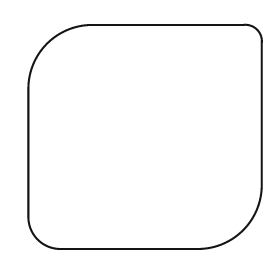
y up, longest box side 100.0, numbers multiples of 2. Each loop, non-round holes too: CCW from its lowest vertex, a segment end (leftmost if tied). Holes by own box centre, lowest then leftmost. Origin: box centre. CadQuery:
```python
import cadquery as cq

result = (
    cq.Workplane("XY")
    .moveTo(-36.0, -48.0)
    .lineTo(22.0, -48.0)
    .threePointArc((42.0, -40.0), (50.0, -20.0))
    .lineTo(50.0, 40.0)
    .threePointArc((48.0, 46.0), (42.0, 48.0))
    .lineTo(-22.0, 48.0)
    .threePointArc((-42.0, 40.0), (-50.0, 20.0))
    .lineTo(-50.0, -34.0)
    .threePointArc((-46.0, -44.0), (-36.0, -48.0))
    .close()
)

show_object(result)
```